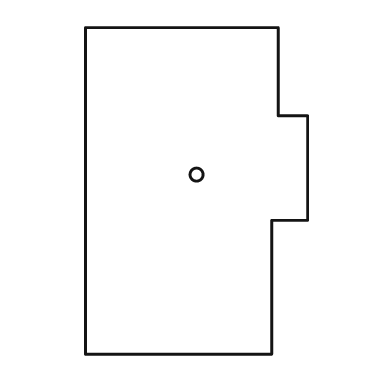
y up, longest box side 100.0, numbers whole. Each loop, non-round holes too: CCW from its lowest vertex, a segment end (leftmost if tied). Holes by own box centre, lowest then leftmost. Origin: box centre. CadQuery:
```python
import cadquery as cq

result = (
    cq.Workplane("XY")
    .moveTo(-34.0, -50.0)
    .lineTo(23.0, -50.0)
    .lineTo(23.0, -9.0)
    .lineTo(34.0, -9.0)
    .lineTo(34.0, 23.0)
    .lineTo(25.0, 23.0)
    .lineTo(25.0, 50.0)
    .lineTo(-34.0, 50.0)
    .close()
    .moveTo(0.0, 5.0)
    .circle(2.0)
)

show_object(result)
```